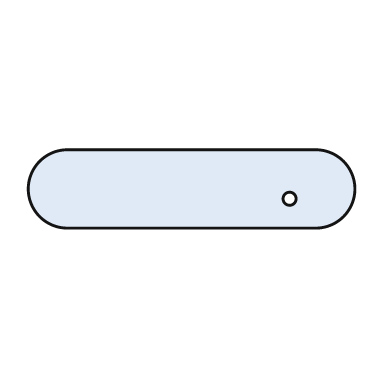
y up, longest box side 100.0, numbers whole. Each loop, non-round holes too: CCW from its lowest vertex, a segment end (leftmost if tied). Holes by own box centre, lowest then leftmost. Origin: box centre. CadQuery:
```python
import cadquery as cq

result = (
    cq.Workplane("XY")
    .moveTo(-38.0, -12.0)
    .lineTo(38.0, -12.0)
    .threePointArc((50.0, 0.0), (38.0, 12.0))
    .lineTo(-38.0, 12.0)
    .threePointArc((-50.0, 0.0), (-38.0, -12.0))
    .close()
    .moveTo(30.0, -3.0)
    .circle(2.0)
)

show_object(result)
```